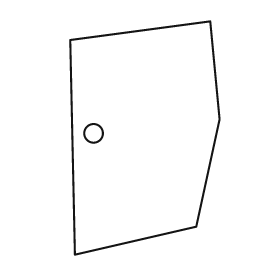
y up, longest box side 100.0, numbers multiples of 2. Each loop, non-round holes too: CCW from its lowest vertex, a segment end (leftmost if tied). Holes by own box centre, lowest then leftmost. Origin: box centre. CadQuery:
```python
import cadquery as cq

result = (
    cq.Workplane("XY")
    .moveTo(-30.0, -50.0)
    .lineTo(22.0, -38.0)
    .lineTo(32.0, 8.0)
    .lineTo(28.0, 50.0)
    .lineTo(-32.0, 42.0)
    .close()
    .moveTo(-22.0, 2.0)
    .circle(4.0)
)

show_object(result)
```